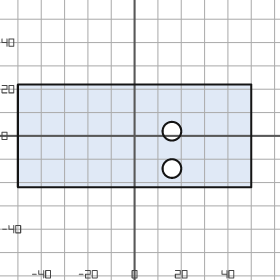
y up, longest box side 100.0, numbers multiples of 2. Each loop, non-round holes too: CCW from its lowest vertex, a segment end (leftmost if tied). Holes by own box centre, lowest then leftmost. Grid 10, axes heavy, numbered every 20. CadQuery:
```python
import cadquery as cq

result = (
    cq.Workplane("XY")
    .moveTo(-50.0, -22.0)
    .lineTo(50.0, -22.0)
    .lineTo(50.0, 22.0)
    .lineTo(-50.0, 22.0)
    .close()
    .moveTo(16.0, -14.0)
    .circle(4.0)
    .moveTo(16.0, 2.0)
    .circle(4.0)
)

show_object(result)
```